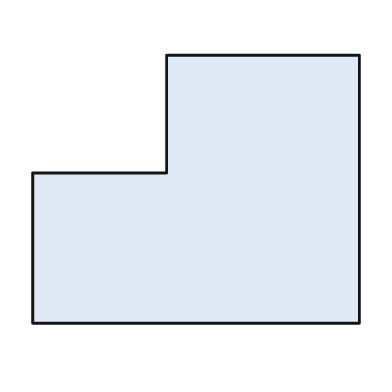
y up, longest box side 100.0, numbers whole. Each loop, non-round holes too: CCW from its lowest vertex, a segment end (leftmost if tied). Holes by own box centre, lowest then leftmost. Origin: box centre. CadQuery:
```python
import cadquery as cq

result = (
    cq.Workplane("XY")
    .moveTo(-50.0, -41.0)
    .lineTo(50.0, -41.0)
    .lineTo(50.0, 41.0)
    .lineTo(-9.0, 41.0)
    .lineTo(-9.0, 5.0)
    .lineTo(-50.0, 5.0)
    .close()
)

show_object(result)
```